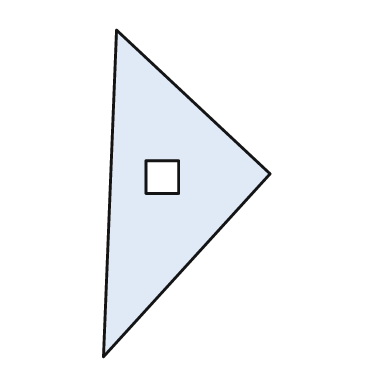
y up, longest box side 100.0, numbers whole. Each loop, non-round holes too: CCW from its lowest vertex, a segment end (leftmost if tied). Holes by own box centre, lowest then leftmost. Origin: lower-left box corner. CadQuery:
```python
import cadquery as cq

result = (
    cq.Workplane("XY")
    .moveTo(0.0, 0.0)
    .lineTo(51.0, 56.0)
    .lineTo(4.0, 100.0)
    .close()
    .moveTo(13.0, 50.0)
    .lineTo(23.0, 50.0)
    .lineTo(23.0, 60.0)
    .lineTo(13.0, 60.0)
    .close()
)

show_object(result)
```